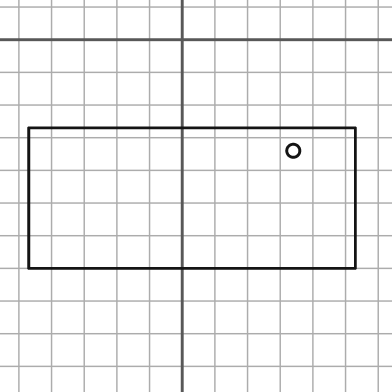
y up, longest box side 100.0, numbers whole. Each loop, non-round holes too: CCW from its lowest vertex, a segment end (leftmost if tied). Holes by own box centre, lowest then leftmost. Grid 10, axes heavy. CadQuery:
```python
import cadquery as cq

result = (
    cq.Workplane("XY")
    .moveTo(-47.0, -70.0)
    .lineTo(53.0, -70.0)
    .lineTo(53.0, -27.0)
    .lineTo(-47.0, -27.0)
    .close()
    .moveTo(34.0, -34.0)
    .circle(2.0)
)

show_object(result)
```